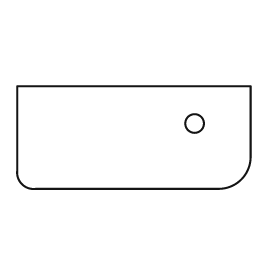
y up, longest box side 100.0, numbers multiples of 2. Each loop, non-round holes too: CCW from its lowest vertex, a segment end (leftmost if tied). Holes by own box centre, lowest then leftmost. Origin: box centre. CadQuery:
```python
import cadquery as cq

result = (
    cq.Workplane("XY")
    .moveTo(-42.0, -22.0)
    .lineTo(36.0, -22.0)
    .threePointArc((46.0, -18.0), (50.0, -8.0))
    .lineTo(50.0, 22.0)
    .lineTo(-50.0, 22.0)
    .lineTo(-50.0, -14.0)
    .threePointArc((-48.0, -20.0), (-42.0, -22.0))
    .close()
    .moveTo(26.0, 6.0)
    .circle(4.0)
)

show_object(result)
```